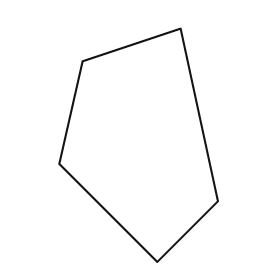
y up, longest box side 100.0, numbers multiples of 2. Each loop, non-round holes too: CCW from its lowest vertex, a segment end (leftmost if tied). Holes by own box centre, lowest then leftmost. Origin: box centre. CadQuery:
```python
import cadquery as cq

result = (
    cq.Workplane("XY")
    .moveTo(8.0, -50.0)
    .lineTo(34.0, -24.0)
    .lineTo(18.0, 50.0)
    .lineTo(-24.0, 36.0)
    .lineTo(-34.0, -8.0)
    .close()
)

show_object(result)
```